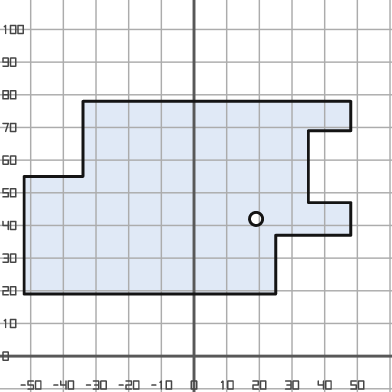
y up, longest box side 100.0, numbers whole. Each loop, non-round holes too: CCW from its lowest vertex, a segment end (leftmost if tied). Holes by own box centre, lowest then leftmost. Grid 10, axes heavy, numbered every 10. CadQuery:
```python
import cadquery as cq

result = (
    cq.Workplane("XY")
    .moveTo(-52.0, 19.0)
    .lineTo(25.0, 19.0)
    .lineTo(25.0, 37.0)
    .lineTo(48.0, 37.0)
    .lineTo(48.0, 47.0)
    .lineTo(35.0, 47.0)
    .lineTo(35.0, 69.0)
    .lineTo(48.0, 69.0)
    .lineTo(48.0, 78.0)
    .lineTo(-34.0, 78.0)
    .lineTo(-34.0, 55.0)
    .lineTo(-52.0, 55.0)
    .close()
    .moveTo(19.0, 42.0)
    .circle(2.0)
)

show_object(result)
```